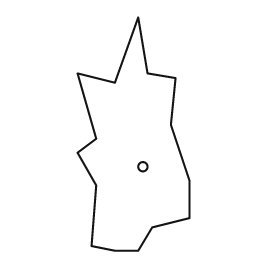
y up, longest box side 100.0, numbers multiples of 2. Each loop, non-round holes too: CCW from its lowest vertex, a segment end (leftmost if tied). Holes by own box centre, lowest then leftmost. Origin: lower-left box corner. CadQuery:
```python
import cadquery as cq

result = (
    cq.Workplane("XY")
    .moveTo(16.0, 0.0)
    .lineTo(26.0, 0.0)
    .lineTo(32.0, 10.0)
    .lineTo(48.0, 14.0)
    .lineTo(48.0, 30.0)
    .lineTo(40.0, 54.0)
    .lineTo(42.0, 74.0)
    .lineTo(30.0, 76.0)
    .lineTo(26.0, 100.0)
    .lineTo(16.0, 72.0)
    .lineTo(0.0, 76.0)
    .lineTo(8.0, 48.0)
    .lineTo(0.0, 42.0)
    .lineTo(8.0, 28.0)
    .lineTo(6.0, 2.0)
    .close()
    .moveTo(28.0, 36.0)
    .circle(2.0)
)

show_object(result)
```